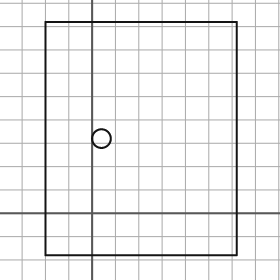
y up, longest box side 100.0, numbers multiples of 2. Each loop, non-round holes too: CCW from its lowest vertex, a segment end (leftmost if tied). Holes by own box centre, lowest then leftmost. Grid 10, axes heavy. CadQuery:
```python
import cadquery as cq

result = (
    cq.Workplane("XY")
    .moveTo(-20.0, -18.0)
    .lineTo(62.0, -18.0)
    .lineTo(62.0, 82.0)
    .lineTo(-20.0, 82.0)
    .close()
    .moveTo(4.0, 32.0)
    .circle(4.0)
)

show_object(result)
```